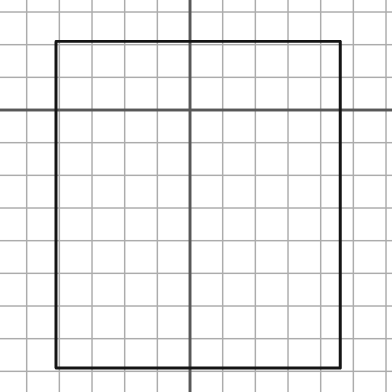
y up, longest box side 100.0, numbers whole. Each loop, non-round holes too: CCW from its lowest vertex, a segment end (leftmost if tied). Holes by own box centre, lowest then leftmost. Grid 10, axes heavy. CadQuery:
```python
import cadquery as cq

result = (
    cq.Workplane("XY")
    .moveTo(-41.0, -79.0)
    .lineTo(46.0, -79.0)
    .lineTo(46.0, 21.0)
    .lineTo(-41.0, 21.0)
    .close()
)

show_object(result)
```